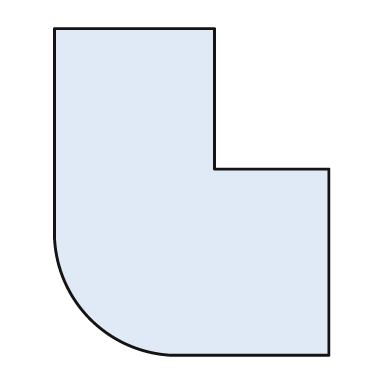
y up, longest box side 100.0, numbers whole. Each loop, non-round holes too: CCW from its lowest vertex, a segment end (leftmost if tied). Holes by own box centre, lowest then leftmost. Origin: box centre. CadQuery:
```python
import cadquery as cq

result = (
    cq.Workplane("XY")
    .moveTo(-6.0, -50.0)
    .lineTo(42.0, -50.0)
    .lineTo(42.0, 7.0)
    .lineTo(7.0, 7.0)
    .lineTo(7.0, 50.0)
    .lineTo(-42.0, 50.0)
    .lineTo(-42.0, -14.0)
    .threePointArc((-31.0, -39.0), (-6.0, -50.0))
    .close()
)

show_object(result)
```